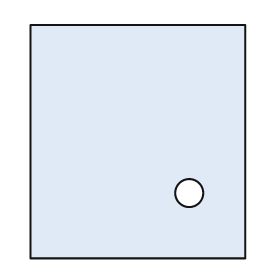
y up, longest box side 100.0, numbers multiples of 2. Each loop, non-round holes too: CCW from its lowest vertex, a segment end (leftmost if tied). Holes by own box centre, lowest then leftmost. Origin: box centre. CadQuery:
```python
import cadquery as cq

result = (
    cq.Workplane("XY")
    .moveTo(-46.0, -50.0)
    .lineTo(46.0, -50.0)
    .lineTo(46.0, 50.0)
    .lineTo(-46.0, 50.0)
    .close()
    .moveTo(22.0, -22.0)
    .circle(6.0)
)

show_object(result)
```